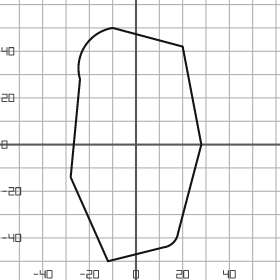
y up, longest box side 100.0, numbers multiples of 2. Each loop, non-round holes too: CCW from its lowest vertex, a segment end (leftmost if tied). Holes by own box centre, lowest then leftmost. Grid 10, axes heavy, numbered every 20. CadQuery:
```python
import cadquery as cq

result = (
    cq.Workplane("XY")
    .moveTo(-12.0, -50.0)
    .lineTo(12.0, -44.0)
    .threePointArc((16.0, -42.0), (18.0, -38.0))
    .lineTo(28.0, 0.0)
    .lineTo(20.0, 42.0)
    .lineTo(-10.0, 50.0)
    .threePointArc((-22.0, 42.0), (-24.0, 28.0))
    .lineTo(-28.0, -14.0)
    .close()
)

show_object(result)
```